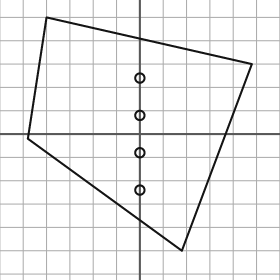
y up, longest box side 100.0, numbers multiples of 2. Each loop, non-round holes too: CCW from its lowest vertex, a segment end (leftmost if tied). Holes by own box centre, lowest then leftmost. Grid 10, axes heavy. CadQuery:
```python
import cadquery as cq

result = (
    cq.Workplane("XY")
    .moveTo(18.0, -50.0)
    .lineTo(48.0, 30.0)
    .lineTo(-40.0, 50.0)
    .lineTo(-48.0, -2.0)
    .close()
    .moveTo(0.0, -24.0)
    .circle(2.0)
    .moveTo(0.0, -8.0)
    .circle(2.0)
    .moveTo(0.0, 8.0)
    .circle(2.0)
    .moveTo(0.0, 24.0)
    .circle(2.0)
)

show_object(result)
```